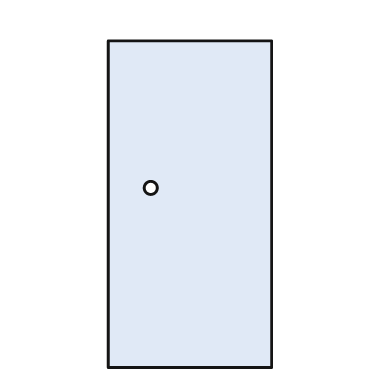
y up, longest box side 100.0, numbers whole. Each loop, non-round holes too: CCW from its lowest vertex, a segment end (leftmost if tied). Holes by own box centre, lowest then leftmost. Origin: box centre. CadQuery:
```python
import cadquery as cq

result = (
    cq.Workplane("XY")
    .moveTo(-25.0, -50.0)
    .lineTo(25.0, -50.0)
    .lineTo(25.0, 50.0)
    .lineTo(-25.0, 50.0)
    .close()
    .moveTo(-12.0, 5.0)
    .circle(2.0)
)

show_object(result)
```